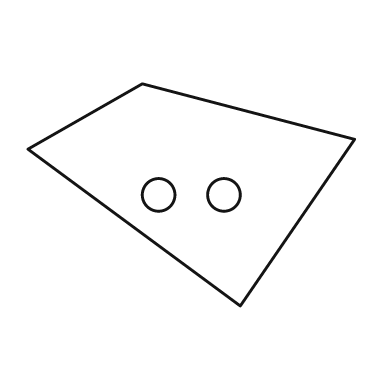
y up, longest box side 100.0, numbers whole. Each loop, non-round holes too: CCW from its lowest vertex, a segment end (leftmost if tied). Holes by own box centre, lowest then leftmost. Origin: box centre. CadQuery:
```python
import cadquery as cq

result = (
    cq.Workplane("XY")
    .moveTo(15.0, -34.0)
    .lineTo(50.0, 17.0)
    .lineTo(-15.0, 34.0)
    .lineTo(-50.0, 14.0)
    .close()
    .moveTo(-10.0, 0.0)
    .circle(5.0)
    .moveTo(10.0, 0.0)
    .circle(5.0)
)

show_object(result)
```